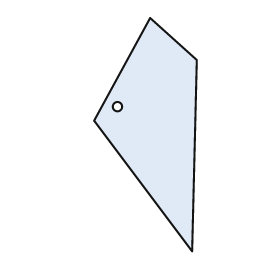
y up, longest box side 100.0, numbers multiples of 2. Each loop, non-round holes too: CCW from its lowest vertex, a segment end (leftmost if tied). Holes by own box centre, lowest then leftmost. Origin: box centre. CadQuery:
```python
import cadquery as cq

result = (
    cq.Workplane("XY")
    .moveTo(20.0, -50.0)
    .lineTo(22.0, 32.0)
    .lineTo(2.0, 50.0)
    .lineTo(-22.0, 6.0)
    .close()
    .moveTo(-12.0, 12.0)
    .circle(2.0)
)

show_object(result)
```